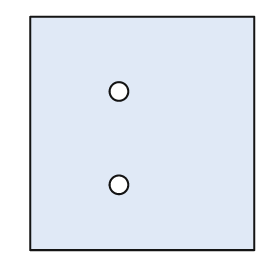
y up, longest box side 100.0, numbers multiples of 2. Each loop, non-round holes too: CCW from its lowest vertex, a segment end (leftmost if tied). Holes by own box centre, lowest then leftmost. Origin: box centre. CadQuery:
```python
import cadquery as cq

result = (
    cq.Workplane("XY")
    .moveTo(-48.0, -50.0)
    .lineTo(48.0, -50.0)
    .lineTo(48.0, 50.0)
    .lineTo(-48.0, 50.0)
    .close()
    .moveTo(-10.0, -22.0)
    .circle(4.0)
    .moveTo(-10.0, 18.0)
    .circle(4.0)
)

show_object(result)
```